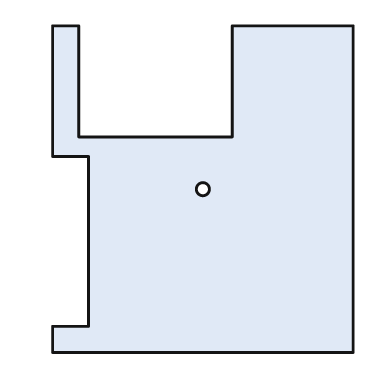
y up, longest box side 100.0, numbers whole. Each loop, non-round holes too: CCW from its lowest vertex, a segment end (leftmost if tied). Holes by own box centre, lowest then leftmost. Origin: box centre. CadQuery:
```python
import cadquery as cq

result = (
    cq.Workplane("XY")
    .moveTo(-46.0, -50.0)
    .lineTo(46.0, -50.0)
    .lineTo(46.0, 50.0)
    .lineTo(9.0, 50.0)
    .lineTo(9.0, 16.0)
    .lineTo(-38.0, 16.0)
    .lineTo(-38.0, 50.0)
    .lineTo(-46.0, 50.0)
    .lineTo(-46.0, 10.0)
    .lineTo(-35.0, 10.0)
    .lineTo(-35.0, -42.0)
    .lineTo(-46.0, -42.0)
    .close()
    .moveTo(0.0, 0.0)
    .circle(2.0)
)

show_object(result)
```